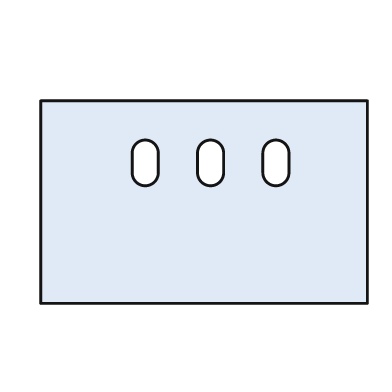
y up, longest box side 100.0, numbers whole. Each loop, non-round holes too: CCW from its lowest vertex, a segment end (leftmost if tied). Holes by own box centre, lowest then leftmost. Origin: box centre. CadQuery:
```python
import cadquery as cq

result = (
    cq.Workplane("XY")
    .moveTo(-50.0, -31.0)
    .lineTo(50.0, -31.0)
    .lineTo(50.0, 31.0)
    .lineTo(-50.0, 31.0)
    .close()
    .moveTo(-22.0, 9.0)
    .threePointArc((-18.0, 5.0), (-14.0, 9.0))
    .lineTo(-14.0, 15.0)
    .threePointArc((-18.0, 19.0), (-22.0, 15.0))
    .close()
    .moveTo(-2.0, 9.0)
    .threePointArc((2.0, 5.0), (6.0, 9.0))
    .lineTo(6.0, 15.0)
    .threePointArc((2.0, 19.0), (-2.0, 15.0))
    .close()
    .moveTo(18.0, 9.0)
    .threePointArc((22.0, 5.0), (26.0, 9.0))
    .lineTo(26.0, 15.0)
    .threePointArc((22.0, 19.0), (18.0, 15.0))
    .close()
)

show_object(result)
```